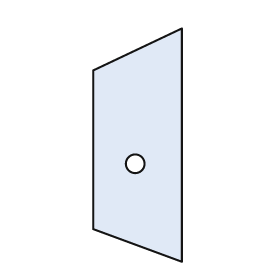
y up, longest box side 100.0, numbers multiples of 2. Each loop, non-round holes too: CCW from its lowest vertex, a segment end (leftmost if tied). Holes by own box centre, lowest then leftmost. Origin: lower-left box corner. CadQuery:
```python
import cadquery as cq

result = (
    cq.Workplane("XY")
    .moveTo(38.0, 0.0)
    .lineTo(38.0, 100.0)
    .lineTo(0.0, 82.0)
    .lineTo(0.0, 14.0)
    .close()
    .moveTo(18.0, 42.0)
    .circle(4.0)
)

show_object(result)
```